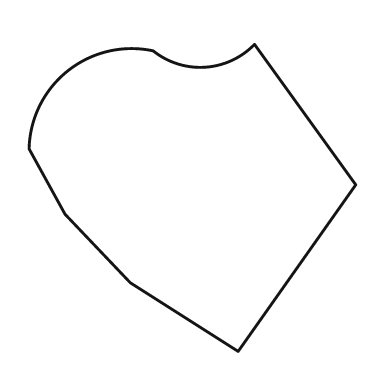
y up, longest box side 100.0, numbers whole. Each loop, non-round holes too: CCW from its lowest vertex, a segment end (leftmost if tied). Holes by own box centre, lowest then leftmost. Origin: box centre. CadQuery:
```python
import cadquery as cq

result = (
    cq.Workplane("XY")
    .moveTo(14.0, -47.0)
    .lineTo(50.0, 4.0)
    .lineTo(19.0, 47.0)
    .threePointArc((4.0, 40.0), (-12.0, 45.0))
    .threePointArc((-38.0, 39.0), (-50.0, 15.0))
    .lineTo(-39.0, -5.0)
    .lineTo(-19.0, -26.0)
    .close()
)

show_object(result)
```